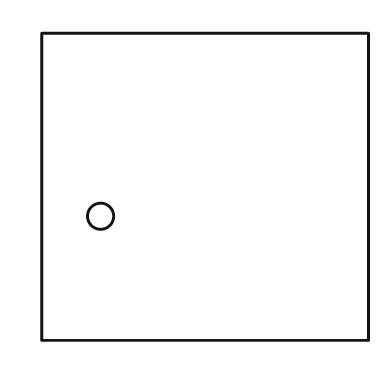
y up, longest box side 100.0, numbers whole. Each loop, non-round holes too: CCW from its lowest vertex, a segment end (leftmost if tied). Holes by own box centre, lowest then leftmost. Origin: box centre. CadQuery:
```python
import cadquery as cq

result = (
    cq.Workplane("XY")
    .moveTo(-50.0, -47.0)
    .lineTo(50.0, -47.0)
    .lineTo(50.0, 47.0)
    .lineTo(-50.0, 47.0)
    .close()
    .moveTo(-32.0, -9.0)
    .circle(4.0)
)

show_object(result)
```